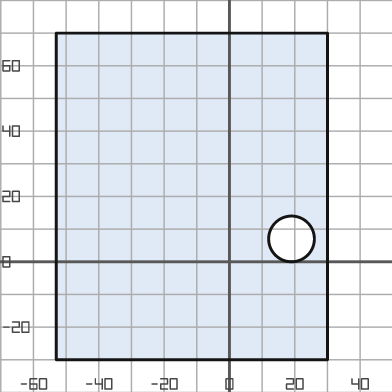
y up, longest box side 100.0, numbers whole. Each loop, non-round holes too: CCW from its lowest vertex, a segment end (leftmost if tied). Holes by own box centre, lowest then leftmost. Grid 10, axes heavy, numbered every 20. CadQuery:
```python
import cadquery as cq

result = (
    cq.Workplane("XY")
    .moveTo(-53.0, -30.0)
    .lineTo(30.0, -30.0)
    .lineTo(30.0, 70.0)
    .lineTo(-53.0, 70.0)
    .close()
    .moveTo(19.0, 7.0)
    .circle(7.0)
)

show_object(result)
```